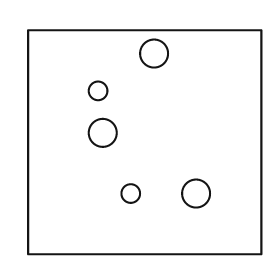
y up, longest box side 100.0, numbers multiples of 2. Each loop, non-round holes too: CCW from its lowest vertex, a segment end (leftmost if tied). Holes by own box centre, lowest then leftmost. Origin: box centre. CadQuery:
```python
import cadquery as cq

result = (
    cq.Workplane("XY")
    .moveTo(-50.0, -48.0)
    .lineTo(50.0, -48.0)
    .lineTo(50.0, 48.0)
    .lineTo(-50.0, 48.0)
    .close()
    .moveTo(-6.0, -22.0)
    .circle(4.0)
    .moveTo(22.0, -22.0)
    .circle(6.0)
    .moveTo(-18.0, 4.0)
    .circle(6.0)
    .moveTo(-20.0, 22.0)
    .circle(4.0)
    .moveTo(4.0, 38.0)
    .circle(6.0)
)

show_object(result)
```